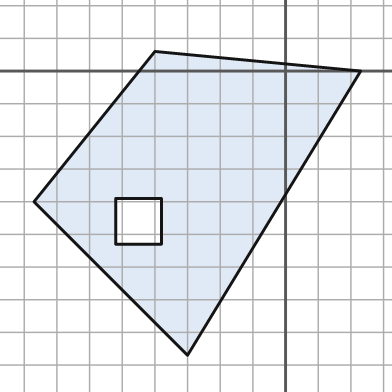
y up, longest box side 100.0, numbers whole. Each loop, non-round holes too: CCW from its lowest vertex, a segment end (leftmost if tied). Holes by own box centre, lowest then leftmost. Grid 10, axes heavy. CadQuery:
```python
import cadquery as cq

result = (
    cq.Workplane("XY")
    .moveTo(-30.0, -87.0)
    .lineTo(23.0, 0.0)
    .lineTo(-40.0, 6.0)
    .lineTo(-77.0, -40.0)
    .close()
    .moveTo(-52.0, -53.0)
    .lineTo(-38.0, -53.0)
    .lineTo(-38.0, -39.0)
    .lineTo(-52.0, -39.0)
    .close()
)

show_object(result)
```